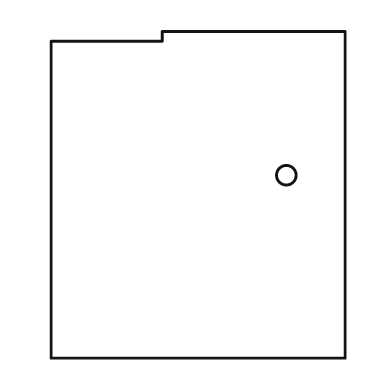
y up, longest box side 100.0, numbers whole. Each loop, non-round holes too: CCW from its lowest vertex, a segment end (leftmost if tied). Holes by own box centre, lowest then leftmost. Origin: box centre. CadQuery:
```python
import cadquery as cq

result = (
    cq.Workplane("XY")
    .moveTo(-45.0, -50.0)
    .lineTo(45.0, -50.0)
    .lineTo(45.0, 50.0)
    .lineTo(-11.0, 50.0)
    .lineTo(-11.0, 47.0)
    .lineTo(-45.0, 47.0)
    .close()
    .moveTo(27.0, 6.0)
    .circle(3.0)
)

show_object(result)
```